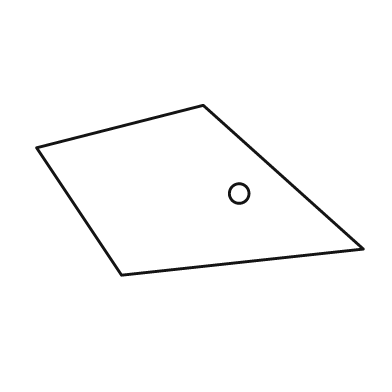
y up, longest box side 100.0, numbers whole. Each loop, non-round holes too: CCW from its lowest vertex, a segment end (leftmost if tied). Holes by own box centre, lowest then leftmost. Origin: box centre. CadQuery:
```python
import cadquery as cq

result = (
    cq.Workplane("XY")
    .moveTo(-24.0, -26.0)
    .lineTo(50.0, -18.0)
    .lineTo(1.0, 26.0)
    .lineTo(-50.0, 13.0)
    .close()
    .moveTo(12.0, -1.0)
    .circle(3.0)
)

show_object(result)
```